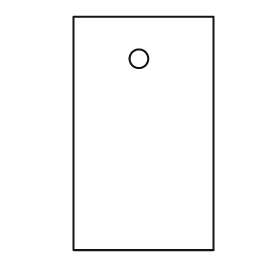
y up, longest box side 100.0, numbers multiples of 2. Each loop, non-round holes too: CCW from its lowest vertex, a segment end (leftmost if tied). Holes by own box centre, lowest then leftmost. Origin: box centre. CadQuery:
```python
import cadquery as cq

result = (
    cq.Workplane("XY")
    .moveTo(-30.0, -50.0)
    .lineTo(30.0, -50.0)
    .lineTo(30.0, 50.0)
    .lineTo(-30.0, 50.0)
    .close()
    .moveTo(-2.0, 32.0)
    .circle(4.0)
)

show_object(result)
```